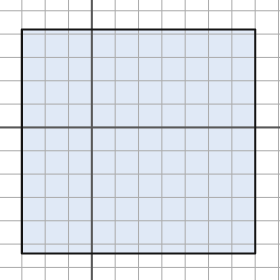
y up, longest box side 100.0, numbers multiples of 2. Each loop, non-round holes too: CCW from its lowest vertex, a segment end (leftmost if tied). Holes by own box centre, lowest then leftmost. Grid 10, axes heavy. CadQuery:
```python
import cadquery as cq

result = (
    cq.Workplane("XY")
    .moveTo(-30.0, -54.0)
    .lineTo(70.0, -54.0)
    .lineTo(70.0, 42.0)
    .lineTo(-30.0, 42.0)
    .close()
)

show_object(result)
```